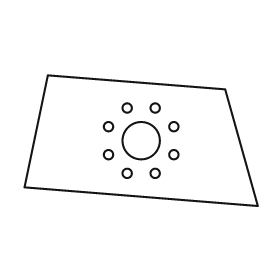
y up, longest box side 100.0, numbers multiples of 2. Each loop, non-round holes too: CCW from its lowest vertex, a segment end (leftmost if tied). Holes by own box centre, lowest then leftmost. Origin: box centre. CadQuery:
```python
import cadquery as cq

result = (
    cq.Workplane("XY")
    .moveTo(50.0, -28.0)
    .lineTo(36.0, 22.0)
    .lineTo(-40.0, 28.0)
    .lineTo(-50.0, -20.0)
    .close()
    .moveTo(-6.0, -14.0)
    .circle(2.0)
    .moveTo(6.0, -14.0)
    .circle(2.0)
    .moveTo(-14.0, -6.0)
    .circle(2.0)
    .moveTo(14.0, -6.0)
    .circle(2.0)
    .moveTo(0.0, 0.0)
    .circle(8.0)
    .moveTo(-14.0, 6.0)
    .circle(2.0)
    .moveTo(14.0, 6.0)
    .circle(2.0)
    .moveTo(-6.0, 14.0)
    .circle(2.0)
    .moveTo(6.0, 14.0)
    .circle(2.0)
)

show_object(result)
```